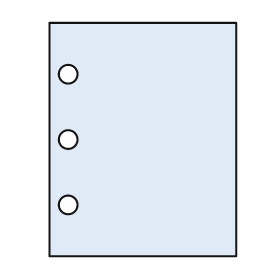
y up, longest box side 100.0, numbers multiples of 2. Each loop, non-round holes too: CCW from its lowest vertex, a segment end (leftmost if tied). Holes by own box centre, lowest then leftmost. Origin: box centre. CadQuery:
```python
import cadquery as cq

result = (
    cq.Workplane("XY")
    .moveTo(-40.0, -50.0)
    .lineTo(40.0, -50.0)
    .lineTo(40.0, 50.0)
    .lineTo(-40.0, 50.0)
    .close()
    .moveTo(-32.0, -28.0)
    .circle(4.0)
    .moveTo(-32.0, 0.0)
    .circle(4.0)
    .moveTo(-32.0, 28.0)
    .circle(4.0)
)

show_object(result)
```